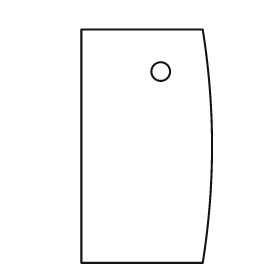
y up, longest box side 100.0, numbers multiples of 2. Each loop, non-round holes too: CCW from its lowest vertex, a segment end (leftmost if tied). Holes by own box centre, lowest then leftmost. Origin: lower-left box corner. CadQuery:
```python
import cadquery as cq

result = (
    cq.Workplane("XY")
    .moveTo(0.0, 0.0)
    .lineTo(52.0, 0.0)
    .threePointArc((56.0, 50.0), (52.0, 100.0))
    .lineTo(0.0, 100.0)
    .close()
    .moveTo(34.0, 82.0)
    .circle(4.0)
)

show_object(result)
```